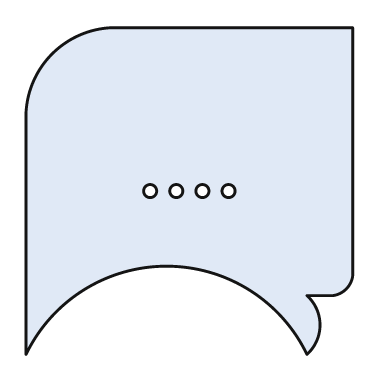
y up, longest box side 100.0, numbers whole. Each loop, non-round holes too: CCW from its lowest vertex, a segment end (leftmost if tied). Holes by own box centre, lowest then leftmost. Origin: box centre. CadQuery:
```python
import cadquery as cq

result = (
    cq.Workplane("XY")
    .moveTo(-50.0, -50.0)
    .threePointArc((-7.0, -23.0), (36.0, -50.0))
    .threePointArc((40.0, -41.0), (36.0, -32.0))
    .lineTo(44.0, -32.0)
    .threePointArc((48.0, -30.0), (50.0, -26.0))
    .lineTo(50.0, 50.0)
    .lineTo(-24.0, 50.0)
    .threePointArc((-42.0, 42.0), (-50.0, 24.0))
    .close()
    .moveTo(-12.0, 0.0)
    .circle(2.0)
    .moveTo(-4.0, 0.0)
    .circle(2.0)
    .moveTo(4.0, 0.0)
    .circle(2.0)
    .moveTo(12.0, 0.0)
    .circle(2.0)
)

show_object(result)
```